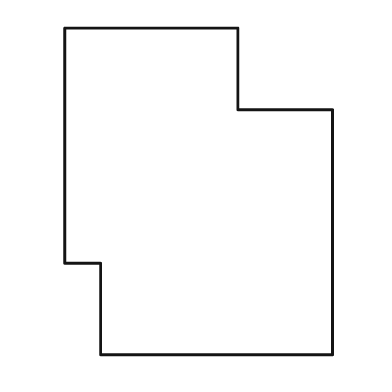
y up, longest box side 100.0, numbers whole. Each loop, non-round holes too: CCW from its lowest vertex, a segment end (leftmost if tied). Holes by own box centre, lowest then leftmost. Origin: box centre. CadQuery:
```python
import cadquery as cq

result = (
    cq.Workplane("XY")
    .moveTo(-30.0, -50.0)
    .lineTo(41.0, -50.0)
    .lineTo(41.0, 25.0)
    .lineTo(12.0, 25.0)
    .lineTo(12.0, 50.0)
    .lineTo(-41.0, 50.0)
    .lineTo(-41.0, -22.0)
    .lineTo(-30.0, -22.0)
    .close()
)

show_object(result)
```